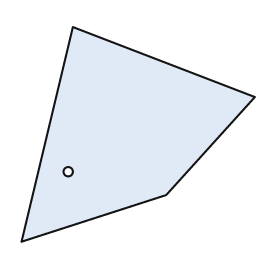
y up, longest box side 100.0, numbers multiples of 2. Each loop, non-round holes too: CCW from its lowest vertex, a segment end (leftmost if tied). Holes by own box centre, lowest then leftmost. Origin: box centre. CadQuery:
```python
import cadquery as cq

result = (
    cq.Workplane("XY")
    .moveTo(-50.0, -46.0)
    .lineTo(12.0, -26.0)
    .lineTo(50.0, 16.0)
    .lineTo(-28.0, 46.0)
    .close()
    .moveTo(-30.0, -16.0)
    .circle(2.0)
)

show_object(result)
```